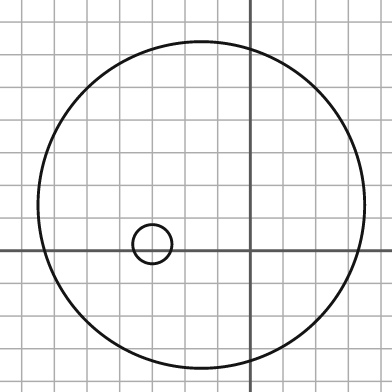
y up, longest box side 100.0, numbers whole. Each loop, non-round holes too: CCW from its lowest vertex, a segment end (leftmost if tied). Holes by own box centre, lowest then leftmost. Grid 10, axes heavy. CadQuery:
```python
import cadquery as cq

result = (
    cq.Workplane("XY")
    .moveTo(-15.0, 14.0)
    .circle(50.0)
    .moveTo(-30.0, 2.0)
    .circle(6.0)
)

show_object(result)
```